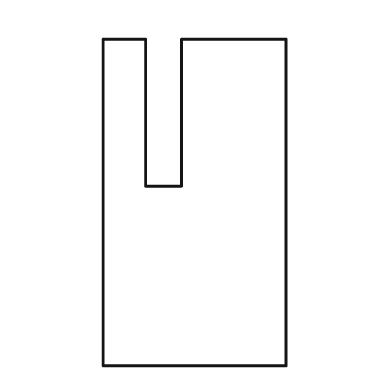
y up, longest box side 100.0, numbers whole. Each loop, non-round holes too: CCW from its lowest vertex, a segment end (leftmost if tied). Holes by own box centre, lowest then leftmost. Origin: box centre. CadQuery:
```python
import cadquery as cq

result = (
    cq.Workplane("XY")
    .moveTo(-28.0, -50.0)
    .lineTo(28.0, -50.0)
    .lineTo(28.0, 50.0)
    .lineTo(-4.0, 50.0)
    .lineTo(-4.0, 5.0)
    .lineTo(-15.0, 5.0)
    .lineTo(-15.0, 50.0)
    .lineTo(-28.0, 50.0)
    .close()
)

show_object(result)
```